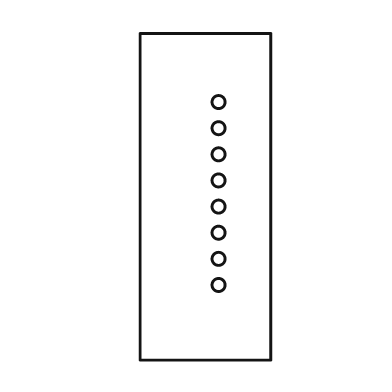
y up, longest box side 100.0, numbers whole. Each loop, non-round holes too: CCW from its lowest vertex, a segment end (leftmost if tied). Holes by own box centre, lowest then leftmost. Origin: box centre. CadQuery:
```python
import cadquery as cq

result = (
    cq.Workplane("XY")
    .moveTo(-20.0, -50.0)
    .lineTo(20.0, -50.0)
    .lineTo(20.0, 50.0)
    .lineTo(-20.0, 50.0)
    .close()
    .moveTo(4.0, -27.0)
    .circle(2.0)
    .moveTo(4.0, -19.0)
    .circle(2.0)
    .moveTo(4.0, -11.0)
    .circle(2.0)
    .moveTo(4.0, -3.0)
    .circle(2.0)
    .moveTo(4.0, 5.0)
    .circle(2.0)
    .moveTo(4.0, 13.0)
    .circle(2.0)
    .moveTo(4.0, 21.0)
    .circle(2.0)
    .moveTo(4.0, 29.0)
    .circle(2.0)
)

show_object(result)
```